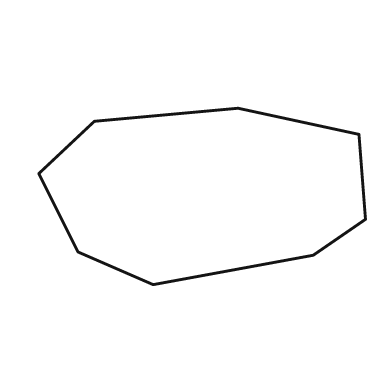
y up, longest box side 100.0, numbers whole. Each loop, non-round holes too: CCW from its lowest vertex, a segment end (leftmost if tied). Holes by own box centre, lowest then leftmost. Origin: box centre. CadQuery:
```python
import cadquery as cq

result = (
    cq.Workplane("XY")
    .moveTo(-15.0, -27.0)
    .lineTo(34.0, -18.0)
    .lineTo(50.0, -7.0)
    .lineTo(48.0, 19.0)
    .lineTo(11.0, 27.0)
    .lineTo(-33.0, 23.0)
    .lineTo(-50.0, 7.0)
    .lineTo(-38.0, -17.0)
    .close()
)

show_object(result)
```